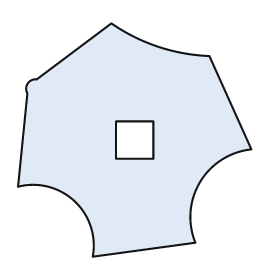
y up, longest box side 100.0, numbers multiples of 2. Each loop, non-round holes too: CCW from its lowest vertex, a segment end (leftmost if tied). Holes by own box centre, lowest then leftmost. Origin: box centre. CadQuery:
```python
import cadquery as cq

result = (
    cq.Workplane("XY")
    .moveTo(-18.0, -50.0)
    .lineTo(26.0, -44.0)
    .threePointArc((28.0, -18.0), (50.0, -4.0))
    .lineTo(32.0, 36.0)
    .threePointArc((10.0, 40.0), (-10.0, 50.0))
    .lineTo(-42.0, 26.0)
    .threePointArc((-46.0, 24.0), (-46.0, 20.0))
    .lineTo(-50.0, -20.0)
    .threePointArc((-26.0, -26.0), (-18.0, -50.0))
    .close()
    .moveTo(-8.0, -8.0)
    .lineTo(8.0, -8.0)
    .lineTo(8.0, 8.0)
    .lineTo(-8.0, 8.0)
    .close()
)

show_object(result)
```